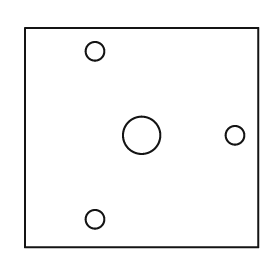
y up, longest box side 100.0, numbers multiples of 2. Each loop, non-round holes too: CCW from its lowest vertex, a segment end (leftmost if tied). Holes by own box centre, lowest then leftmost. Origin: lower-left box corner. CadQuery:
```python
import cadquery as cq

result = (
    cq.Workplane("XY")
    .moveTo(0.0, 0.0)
    .lineTo(100.0, 0.0)
    .lineTo(100.0, 94.0)
    .lineTo(0.0, 94.0)
    .close()
    .moveTo(30.0, 12.0)
    .circle(4.0)
    .moveTo(50.0, 48.0)
    .circle(8.0)
    .moveTo(90.0, 48.0)
    .circle(4.0)
    .moveTo(30.0, 84.0)
    .circle(4.0)
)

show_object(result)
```